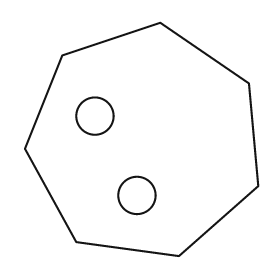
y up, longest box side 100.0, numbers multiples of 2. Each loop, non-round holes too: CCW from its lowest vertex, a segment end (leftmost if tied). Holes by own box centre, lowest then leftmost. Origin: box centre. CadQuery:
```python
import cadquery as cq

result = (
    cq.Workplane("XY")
    .moveTo(16.0, -50.0)
    .lineTo(50.0, -20.0)
    .lineTo(46.0, 24.0)
    .lineTo(8.0, 50.0)
    .lineTo(-34.0, 36.0)
    .lineTo(-50.0, -4.0)
    .lineTo(-28.0, -44.0)
    .close()
    .moveTo(-2.0, -24.0)
    .circle(8.0)
    .moveTo(-20.0, 10.0)
    .circle(8.0)
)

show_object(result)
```